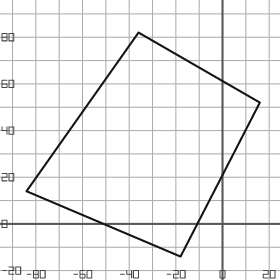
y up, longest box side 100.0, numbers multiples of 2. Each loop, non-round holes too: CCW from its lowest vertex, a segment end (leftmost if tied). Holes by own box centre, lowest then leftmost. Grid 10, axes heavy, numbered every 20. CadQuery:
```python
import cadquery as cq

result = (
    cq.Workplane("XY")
    .moveTo(-18.0, -14.0)
    .lineTo(16.0, 52.0)
    .lineTo(-36.0, 82.0)
    .lineTo(-84.0, 14.0)
    .close()
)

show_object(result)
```